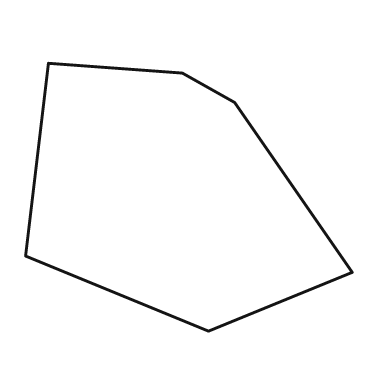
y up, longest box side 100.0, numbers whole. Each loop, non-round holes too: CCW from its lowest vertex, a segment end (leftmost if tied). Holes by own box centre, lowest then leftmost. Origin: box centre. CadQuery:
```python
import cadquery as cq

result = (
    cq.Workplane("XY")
    .moveTo(6.0, -41.0)
    .lineTo(50.0, -23.0)
    .lineTo(14.0, 29.0)
    .lineTo(-2.0, 38.0)
    .lineTo(-43.0, 41.0)
    .lineTo(-50.0, -18.0)
    .close()
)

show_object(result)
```